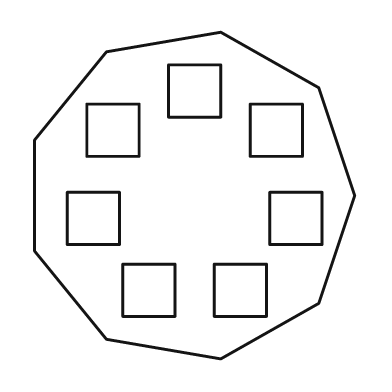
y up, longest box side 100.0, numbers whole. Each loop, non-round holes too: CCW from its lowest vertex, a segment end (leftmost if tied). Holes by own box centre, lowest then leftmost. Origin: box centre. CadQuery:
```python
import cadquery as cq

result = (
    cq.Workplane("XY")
    .moveTo(8.0, -50.0)
    .lineTo(38.0, -33.0)
    .lineTo(49.0, 0.0)
    .lineTo(38.0, 33.0)
    .lineTo(8.0, 50.0)
    .lineTo(-27.0, 44.0)
    .lineTo(-49.0, 17.0)
    .lineTo(-49.0, -17.0)
    .lineTo(-27.0, -44.0)
    .close()
    .moveTo(-22.0, -37.0)
    .lineTo(-6.0, -37.0)
    .lineTo(-6.0, -21.0)
    .lineTo(-22.0, -21.0)
    .close()
    .moveTo(6.0, -37.0)
    .lineTo(22.0, -37.0)
    .lineTo(22.0, -21.0)
    .lineTo(6.0, -21.0)
    .close()
    .moveTo(-39.0, -15.0)
    .lineTo(-23.0, -15.0)
    .lineTo(-23.0, 1.0)
    .lineTo(-39.0, 1.0)
    .close()
    .moveTo(23.0, -15.0)
    .lineTo(39.0, -15.0)
    .lineTo(39.0, 1.0)
    .lineTo(23.0, 1.0)
    .close()
    .moveTo(-33.0, 12.0)
    .lineTo(-17.0, 12.0)
    .lineTo(-17.0, 28.0)
    .lineTo(-33.0, 28.0)
    .close()
    .moveTo(17.0, 12.0)
    .lineTo(33.0, 12.0)
    .lineTo(33.0, 28.0)
    .lineTo(17.0, 28.0)
    .close()
    .moveTo(-8.0, 24.0)
    .lineTo(8.0, 24.0)
    .lineTo(8.0, 40.0)
    .lineTo(-8.0, 40.0)
    .close()
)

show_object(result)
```